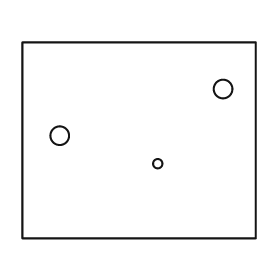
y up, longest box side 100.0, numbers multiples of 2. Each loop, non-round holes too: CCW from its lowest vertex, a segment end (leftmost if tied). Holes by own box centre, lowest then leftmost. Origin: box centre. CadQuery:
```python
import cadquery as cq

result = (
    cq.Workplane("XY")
    .moveTo(-50.0, -42.0)
    .lineTo(50.0, -42.0)
    .lineTo(50.0, 42.0)
    .lineTo(-50.0, 42.0)
    .close()
    .moveTo(8.0, -10.0)
    .circle(2.0)
    .moveTo(-34.0, 2.0)
    .circle(4.0)
    .moveTo(36.0, 22.0)
    .circle(4.0)
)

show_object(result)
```